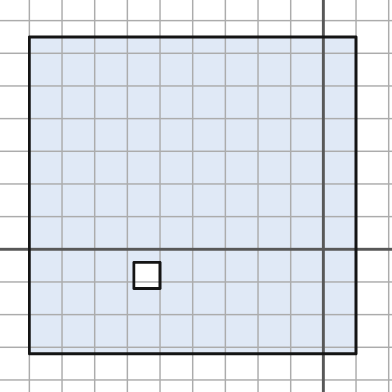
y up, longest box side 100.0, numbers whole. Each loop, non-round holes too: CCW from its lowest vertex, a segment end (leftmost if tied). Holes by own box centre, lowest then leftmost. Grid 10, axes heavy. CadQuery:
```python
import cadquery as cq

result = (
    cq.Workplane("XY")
    .moveTo(-90.0, -32.0)
    .lineTo(10.0, -32.0)
    .lineTo(10.0, 65.0)
    .lineTo(-90.0, 65.0)
    .close()
    .moveTo(-58.0, -12.0)
    .lineTo(-50.0, -12.0)
    .lineTo(-50.0, -4.0)
    .lineTo(-58.0, -4.0)
    .close()
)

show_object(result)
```